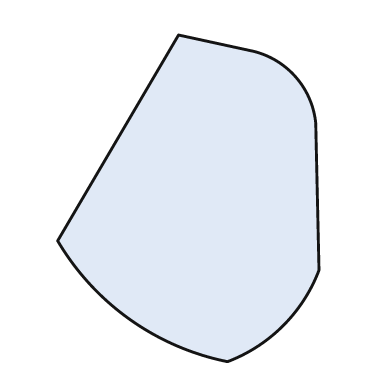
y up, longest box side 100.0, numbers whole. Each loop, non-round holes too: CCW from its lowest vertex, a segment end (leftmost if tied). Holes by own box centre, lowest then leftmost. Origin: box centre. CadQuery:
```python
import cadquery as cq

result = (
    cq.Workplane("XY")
    .moveTo(12.0, -50.0)
    .threePointArc((29.0, -39.0), (40.0, -22.0))
    .lineTo(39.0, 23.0)
    .threePointArc((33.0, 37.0), (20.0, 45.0))
    .lineTo(-3.0, 50.0)
    .lineTo(-40.0, -13.0)
    .threePointArc((-18.0, -37.0), (12.0, -50.0))
    .close()
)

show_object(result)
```